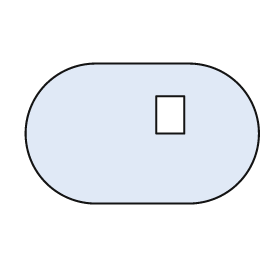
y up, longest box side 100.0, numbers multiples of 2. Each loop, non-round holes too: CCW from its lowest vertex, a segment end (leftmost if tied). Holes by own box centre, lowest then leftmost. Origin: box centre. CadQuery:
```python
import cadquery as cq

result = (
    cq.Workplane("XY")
    .moveTo(-20.0, -30.0)
    .lineTo(20.0, -30.0)
    .threePointArc((50.0, 0.0), (20.0, 30.0))
    .lineTo(-20.0, 30.0)
    .threePointArc((-50.0, 0.0), (-20.0, -30.0))
    .close()
    .moveTo(6.0, 0.0)
    .lineTo(18.0, 0.0)
    .lineTo(18.0, 16.0)
    .lineTo(6.0, 16.0)
    .close()
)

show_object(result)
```